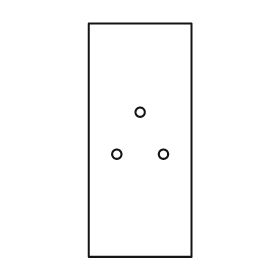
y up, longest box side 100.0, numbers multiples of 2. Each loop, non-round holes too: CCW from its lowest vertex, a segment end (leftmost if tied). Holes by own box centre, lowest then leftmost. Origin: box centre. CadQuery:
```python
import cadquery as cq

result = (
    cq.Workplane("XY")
    .moveTo(-22.0, -50.0)
    .lineTo(22.0, -50.0)
    .lineTo(22.0, 50.0)
    .lineTo(-22.0, 50.0)
    .close()
    .moveTo(-10.0, -6.0)
    .circle(2.0)
    .moveTo(10.0, -6.0)
    .circle(2.0)
    .moveTo(0.0, 12.0)
    .circle(2.0)
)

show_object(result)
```